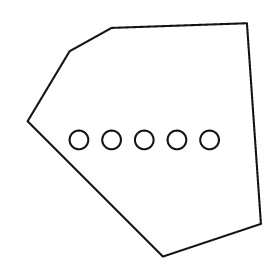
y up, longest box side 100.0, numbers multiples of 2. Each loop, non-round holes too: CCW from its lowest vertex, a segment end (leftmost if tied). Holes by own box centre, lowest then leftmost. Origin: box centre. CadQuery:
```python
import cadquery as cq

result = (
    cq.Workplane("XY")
    .moveTo(8.0, -50.0)
    .lineTo(50.0, -36.0)
    .lineTo(44.0, 50.0)
    .lineTo(-14.0, 48.0)
    .lineTo(-32.0, 38.0)
    .lineTo(-50.0, 8.0)
    .close()
    .moveTo(-28.0, 0.0)
    .circle(4.0)
    .moveTo(-14.0, 0.0)
    .circle(4.0)
    .moveTo(0.0, 0.0)
    .circle(4.0)
    .moveTo(14.0, 0.0)
    .circle(4.0)
    .moveTo(28.0, 0.0)
    .circle(4.0)
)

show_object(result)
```